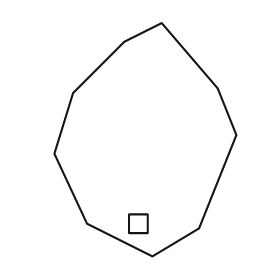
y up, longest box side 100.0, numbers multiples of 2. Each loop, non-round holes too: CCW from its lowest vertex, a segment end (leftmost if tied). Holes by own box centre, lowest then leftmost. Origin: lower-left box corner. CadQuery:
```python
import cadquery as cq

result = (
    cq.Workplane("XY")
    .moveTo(42.0, 0.0)
    .lineTo(62.0, 12.0)
    .lineTo(78.0, 52.0)
    .lineTo(70.0, 72.0)
    .lineTo(46.0, 100.0)
    .lineTo(30.0, 92.0)
    .lineTo(8.0, 70.0)
    .lineTo(0.0, 44.0)
    .lineTo(14.0, 14.0)
    .close()
    .moveTo(32.0, 10.0)
    .lineTo(40.0, 10.0)
    .lineTo(40.0, 18.0)
    .lineTo(32.0, 18.0)
    .close()
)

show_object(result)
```